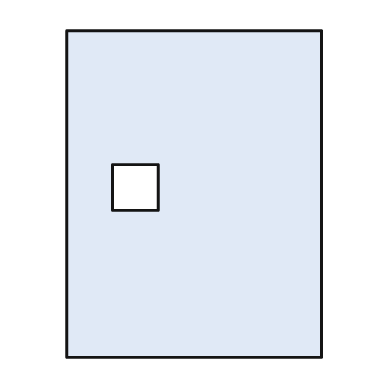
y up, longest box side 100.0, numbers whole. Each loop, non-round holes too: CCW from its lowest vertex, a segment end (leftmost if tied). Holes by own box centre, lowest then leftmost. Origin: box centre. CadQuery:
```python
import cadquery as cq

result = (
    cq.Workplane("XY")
    .moveTo(-39.0, -50.0)
    .lineTo(39.0, -50.0)
    .lineTo(39.0, 50.0)
    .lineTo(-39.0, 50.0)
    .close()
    .moveTo(-25.0, -5.0)
    .lineTo(-11.0, -5.0)
    .lineTo(-11.0, 9.0)
    .lineTo(-25.0, 9.0)
    .close()
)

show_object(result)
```